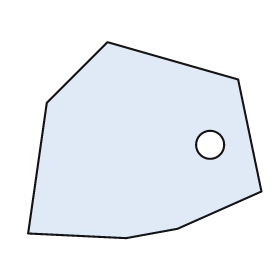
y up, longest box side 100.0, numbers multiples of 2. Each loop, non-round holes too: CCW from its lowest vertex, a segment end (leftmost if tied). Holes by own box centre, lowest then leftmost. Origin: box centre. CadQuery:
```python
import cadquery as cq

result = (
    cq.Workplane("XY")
    .moveTo(-8.0, -42.0)
    .lineTo(14.0, -38.0)
    .lineTo(50.0, -22.0)
    .lineTo(40.0, 26.0)
    .lineTo(-16.0, 42.0)
    .lineTo(-42.0, 16.0)
    .lineTo(-50.0, -40.0)
    .close()
    .moveTo(28.0, -2.0)
    .circle(6.0)
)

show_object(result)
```